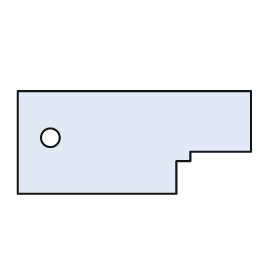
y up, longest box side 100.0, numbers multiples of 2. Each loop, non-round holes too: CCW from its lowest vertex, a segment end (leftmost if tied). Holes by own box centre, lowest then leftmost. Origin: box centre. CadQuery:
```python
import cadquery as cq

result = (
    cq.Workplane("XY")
    .moveTo(-50.0, -22.0)
    .lineTo(18.0, -22.0)
    .lineTo(18.0, -8.0)
    .lineTo(24.0, -8.0)
    .lineTo(24.0, -4.0)
    .lineTo(50.0, -4.0)
    .lineTo(50.0, 22.0)
    .lineTo(-50.0, 22.0)
    .close()
    .moveTo(-36.0, 2.0)
    .circle(4.0)
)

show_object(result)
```